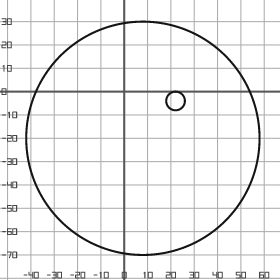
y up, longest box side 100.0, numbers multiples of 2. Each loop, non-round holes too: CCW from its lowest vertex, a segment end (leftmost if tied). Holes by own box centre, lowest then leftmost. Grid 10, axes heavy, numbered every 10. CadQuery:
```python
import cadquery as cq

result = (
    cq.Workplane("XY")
    .moveTo(8.0, -20.0)
    .circle(50.0)
    .moveTo(22.0, -4.0)
    .circle(4.0)
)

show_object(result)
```